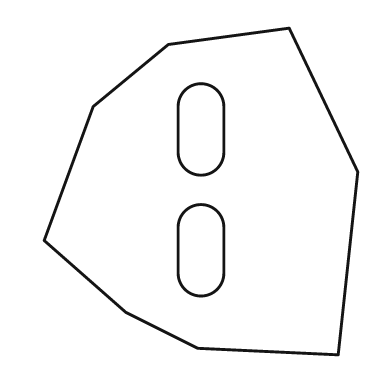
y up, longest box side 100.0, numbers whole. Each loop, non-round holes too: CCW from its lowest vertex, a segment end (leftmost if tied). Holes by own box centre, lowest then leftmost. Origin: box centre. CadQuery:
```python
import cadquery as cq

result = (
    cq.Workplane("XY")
    .moveTo(42.0, -50.0)
    .lineTo(48.0, 6.0)
    .lineTo(27.0, 50.0)
    .lineTo(-10.0, 45.0)
    .lineTo(-33.0, 26.0)
    .lineTo(-48.0, -15.0)
    .lineTo(-23.0, -37.0)
    .lineTo(-1.0, -48.0)
    .close()
    .moveTo(-7.0, -25.0)
    .threePointArc((0.0, -32.0), (7.0, -25.0))
    .lineTo(7.0, -11.0)
    .threePointArc((0.0, -4.0), (-7.0, -11.0))
    .close()
    .moveTo(-7.0, 12.0)
    .threePointArc((0.0, 5.0), (7.0, 12.0))
    .lineTo(7.0, 26.0)
    .threePointArc((0.0, 33.0), (-7.0, 26.0))
    .close()
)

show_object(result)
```